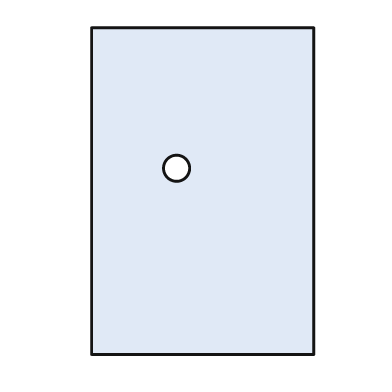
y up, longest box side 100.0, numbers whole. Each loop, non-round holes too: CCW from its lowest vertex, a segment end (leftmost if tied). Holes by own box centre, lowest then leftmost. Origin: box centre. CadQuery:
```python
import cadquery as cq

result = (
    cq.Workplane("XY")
    .moveTo(-34.0, -50.0)
    .lineTo(34.0, -50.0)
    .lineTo(34.0, 50.0)
    .lineTo(-34.0, 50.0)
    .close()
    .moveTo(-8.0, 7.0)
    .circle(4.0)
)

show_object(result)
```